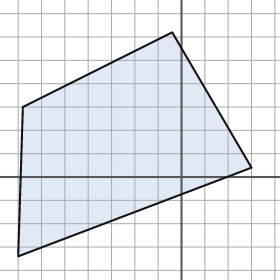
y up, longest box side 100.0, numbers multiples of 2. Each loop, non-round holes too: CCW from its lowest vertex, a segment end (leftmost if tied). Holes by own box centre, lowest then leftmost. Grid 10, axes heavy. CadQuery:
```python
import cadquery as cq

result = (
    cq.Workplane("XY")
    .moveTo(-70.0, -34.0)
    .lineTo(30.0, 4.0)
    .lineTo(-4.0, 62.0)
    .lineTo(-68.0, 30.0)
    .close()
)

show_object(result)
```